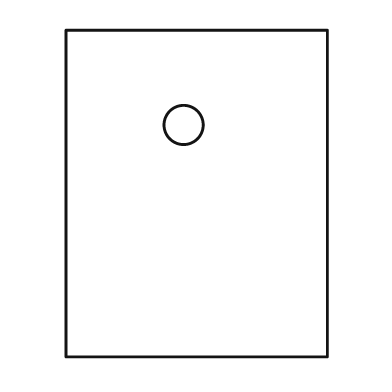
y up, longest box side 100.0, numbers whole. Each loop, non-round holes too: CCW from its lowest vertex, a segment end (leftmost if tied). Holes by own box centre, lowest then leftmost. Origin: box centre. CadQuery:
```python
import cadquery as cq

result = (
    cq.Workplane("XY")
    .moveTo(-40.0, -50.0)
    .lineTo(40.0, -50.0)
    .lineTo(40.0, 50.0)
    .lineTo(-40.0, 50.0)
    .close()
    .moveTo(-4.0, 21.0)
    .circle(6.0)
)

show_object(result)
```